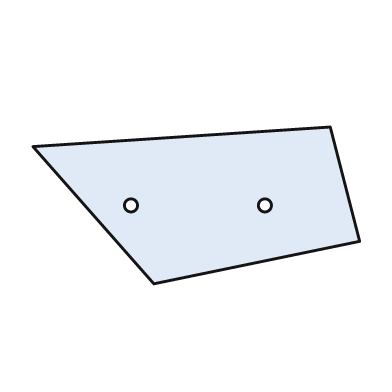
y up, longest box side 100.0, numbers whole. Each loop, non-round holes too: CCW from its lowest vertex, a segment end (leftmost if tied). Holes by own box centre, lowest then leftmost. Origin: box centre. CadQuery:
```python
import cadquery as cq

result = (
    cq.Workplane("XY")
    .moveTo(-13.0, -24.0)
    .lineTo(50.0, -11.0)
    .lineTo(41.0, 24.0)
    .lineTo(-50.0, 18.0)
    .close()
    .moveTo(-20.0, 0.0)
    .circle(2.0)
    .moveTo(21.0, 0.0)
    .circle(2.0)
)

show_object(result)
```